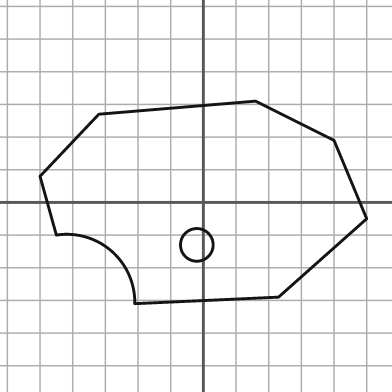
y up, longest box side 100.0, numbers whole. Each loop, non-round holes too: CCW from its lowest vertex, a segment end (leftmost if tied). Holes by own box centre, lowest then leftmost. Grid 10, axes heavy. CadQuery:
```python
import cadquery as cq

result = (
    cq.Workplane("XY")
    .moveTo(-21.0, -31.0)
    .lineTo(23.0, -29.0)
    .lineTo(50.0, -5.0)
    .lineTo(40.0, 19.0)
    .lineTo(16.0, 31.0)
    .lineTo(-32.0, 27.0)
    .lineTo(-50.0, 8.0)
    .lineTo(-45.0, -10.0)
    .threePointArc((-28.0, -15.0), (-21.0, -31.0))
    .close()
    .moveTo(-2.0, -13.0)
    .circle(5.0)
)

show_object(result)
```